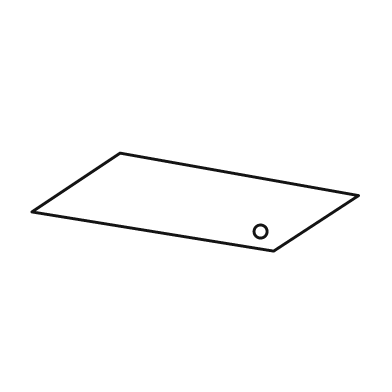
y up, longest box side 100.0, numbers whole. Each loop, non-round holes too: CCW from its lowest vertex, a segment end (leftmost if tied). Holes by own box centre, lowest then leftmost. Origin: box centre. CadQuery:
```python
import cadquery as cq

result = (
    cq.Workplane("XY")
    .moveTo(24.0, -15.0)
    .lineTo(50.0, 2.0)
    .lineTo(-23.0, 15.0)
    .lineTo(-50.0, -3.0)
    .close()
    .moveTo(20.0, -9.0)
    .circle(2.0)
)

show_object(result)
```